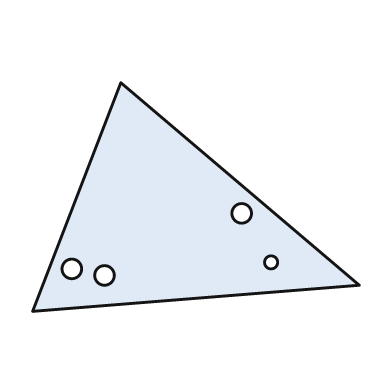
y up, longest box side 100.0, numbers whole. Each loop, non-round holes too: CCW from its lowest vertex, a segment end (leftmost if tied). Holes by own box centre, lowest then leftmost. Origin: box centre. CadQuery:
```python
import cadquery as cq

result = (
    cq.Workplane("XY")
    .moveTo(-50.0, -35.0)
    .lineTo(50.0, -27.0)
    .lineTo(-23.0, 35.0)
    .close()
    .moveTo(-28.0, -24.0)
    .circle(3.0)
    .moveTo(-38.0, -22.0)
    .circle(3.0)
    .moveTo(23.0, -20.0)
    .circle(2.0)
    .moveTo(14.0, -5.0)
    .circle(3.0)
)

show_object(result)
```